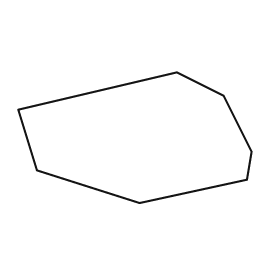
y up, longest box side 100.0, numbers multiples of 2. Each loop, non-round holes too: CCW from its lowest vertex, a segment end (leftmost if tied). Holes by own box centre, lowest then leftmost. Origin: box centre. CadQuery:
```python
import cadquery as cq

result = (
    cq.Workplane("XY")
    .moveTo(2.0, -28.0)
    .lineTo(48.0, -18.0)
    .lineTo(50.0, -6.0)
    .lineTo(38.0, 18.0)
    .lineTo(18.0, 28.0)
    .lineTo(-50.0, 12.0)
    .lineTo(-42.0, -14.0)
    .close()
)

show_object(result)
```